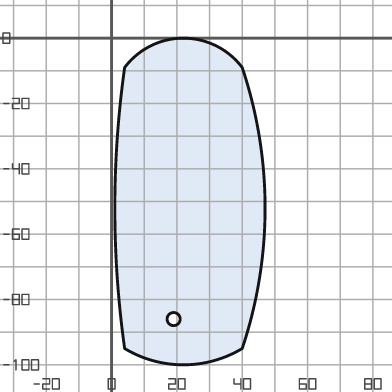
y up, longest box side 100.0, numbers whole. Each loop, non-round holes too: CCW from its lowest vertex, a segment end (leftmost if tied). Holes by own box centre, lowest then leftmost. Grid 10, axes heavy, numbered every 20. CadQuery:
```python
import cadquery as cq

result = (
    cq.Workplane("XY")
    .moveTo(4.0, -95.0)
    .threePointArc((22.0, -100.0), (40.0, -95.0))
    .threePointArc((47.0, -52.0), (40.0, -9.0))
    .threePointArc((22.0, 0.0), (4.0, -9.0))
    .threePointArc((1.0, -52.0), (4.0, -95.0))
    .close()
    .moveTo(19.0, -86.0)
    .circle(2.0)
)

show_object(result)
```